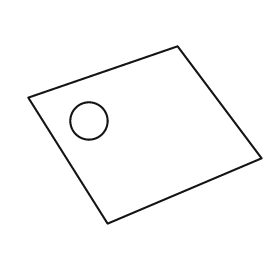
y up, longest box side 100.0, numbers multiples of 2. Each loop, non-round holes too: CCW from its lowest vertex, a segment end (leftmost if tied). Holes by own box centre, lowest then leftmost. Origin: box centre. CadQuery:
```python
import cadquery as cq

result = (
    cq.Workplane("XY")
    .moveTo(-16.0, -38.0)
    .lineTo(50.0, -10.0)
    .lineTo(14.0, 38.0)
    .lineTo(-50.0, 16.0)
    .close()
    .moveTo(-24.0, 6.0)
    .circle(8.0)
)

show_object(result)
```